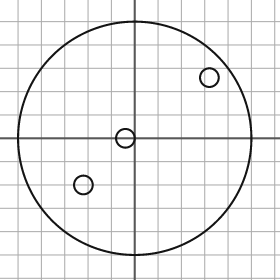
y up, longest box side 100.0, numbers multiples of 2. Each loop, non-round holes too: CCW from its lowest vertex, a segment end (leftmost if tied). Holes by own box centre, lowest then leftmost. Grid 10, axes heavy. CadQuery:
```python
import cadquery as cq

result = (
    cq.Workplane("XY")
    .moveTo(0.0, 0.0)
    .circle(50.0)
    .moveTo(-22.0, -20.0)
    .circle(4.0)
    .moveTo(-4.0, 0.0)
    .circle(4.0)
    .moveTo(32.0, 26.0)
    .circle(4.0)
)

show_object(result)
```